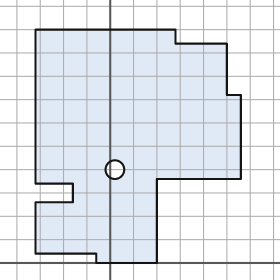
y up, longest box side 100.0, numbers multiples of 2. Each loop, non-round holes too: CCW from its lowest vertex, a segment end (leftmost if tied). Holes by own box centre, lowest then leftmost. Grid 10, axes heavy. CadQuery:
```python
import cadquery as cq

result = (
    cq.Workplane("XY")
    .moveTo(-6.0, 0.0)
    .lineTo(20.0, 0.0)
    .lineTo(20.0, 36.0)
    .lineTo(56.0, 36.0)
    .lineTo(56.0, 72.0)
    .lineTo(50.0, 72.0)
    .lineTo(50.0, 94.0)
    .lineTo(28.0, 94.0)
    .lineTo(28.0, 100.0)
    .lineTo(-32.0, 100.0)
    .lineTo(-32.0, 34.0)
    .lineTo(-16.0, 34.0)
    .lineTo(-16.0, 26.0)
    .lineTo(-32.0, 26.0)
    .lineTo(-32.0, 4.0)
    .lineTo(-6.0, 4.0)
    .close()
    .moveTo(2.0, 40.0)
    .circle(4.0)
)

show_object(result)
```